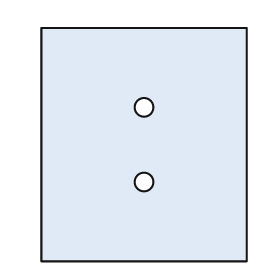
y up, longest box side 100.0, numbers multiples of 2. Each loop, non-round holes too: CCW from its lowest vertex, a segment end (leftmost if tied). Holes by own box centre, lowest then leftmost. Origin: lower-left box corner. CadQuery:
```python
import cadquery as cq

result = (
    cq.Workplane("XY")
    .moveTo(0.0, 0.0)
    .lineTo(88.0, 0.0)
    .lineTo(88.0, 100.0)
    .lineTo(0.0, 100.0)
    .close()
    .moveTo(44.0, 34.0)
    .circle(4.0)
    .moveTo(44.0, 66.0)
    .circle(4.0)
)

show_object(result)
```